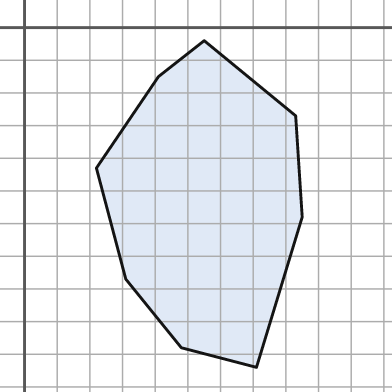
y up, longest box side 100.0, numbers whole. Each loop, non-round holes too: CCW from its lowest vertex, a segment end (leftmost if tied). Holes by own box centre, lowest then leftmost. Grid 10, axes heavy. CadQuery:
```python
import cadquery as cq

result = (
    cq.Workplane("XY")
    .moveTo(71.0, -104.0)
    .lineTo(85.0, -58.0)
    .lineTo(83.0, -27.0)
    .lineTo(55.0, -4.0)
    .lineTo(41.0, -15.0)
    .lineTo(22.0, -43.0)
    .lineTo(31.0, -77.0)
    .lineTo(48.0, -98.0)
    .close()
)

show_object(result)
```